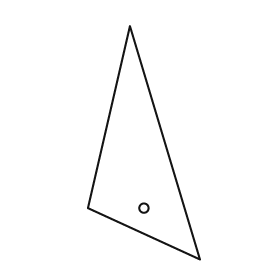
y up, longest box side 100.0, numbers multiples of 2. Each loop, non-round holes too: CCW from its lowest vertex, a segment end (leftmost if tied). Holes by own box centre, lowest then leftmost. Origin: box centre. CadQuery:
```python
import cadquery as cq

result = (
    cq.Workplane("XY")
    .moveTo(24.0, -50.0)
    .lineTo(-6.0, 50.0)
    .lineTo(-24.0, -28.0)
    .close()
    .moveTo(0.0, -28.0)
    .circle(2.0)
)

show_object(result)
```